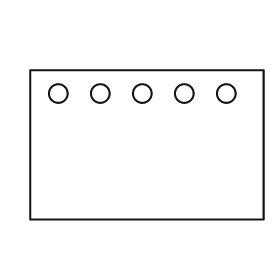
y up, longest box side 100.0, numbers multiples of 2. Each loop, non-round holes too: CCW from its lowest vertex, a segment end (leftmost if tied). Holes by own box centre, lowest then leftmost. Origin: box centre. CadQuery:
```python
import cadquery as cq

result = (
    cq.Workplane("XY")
    .moveTo(-50.0, -32.0)
    .lineTo(50.0, -32.0)
    .lineTo(50.0, 32.0)
    .lineTo(-50.0, 32.0)
    .close()
    .moveTo(-38.0, 22.0)
    .circle(4.0)
    .moveTo(-20.0, 22.0)
    .circle(4.0)
    .moveTo(-2.0, 22.0)
    .circle(4.0)
    .moveTo(16.0, 22.0)
    .circle(4.0)
    .moveTo(34.0, 22.0)
    .circle(4.0)
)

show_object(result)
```